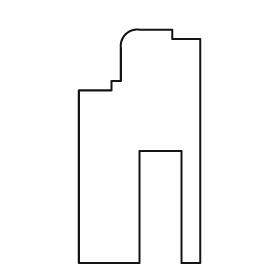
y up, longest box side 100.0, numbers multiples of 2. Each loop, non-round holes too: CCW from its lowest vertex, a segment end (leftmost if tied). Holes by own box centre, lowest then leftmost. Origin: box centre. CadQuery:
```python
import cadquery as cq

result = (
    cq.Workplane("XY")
    .moveTo(-26.0, -50.0)
    .lineTo(0.0, -50.0)
    .lineTo(0.0, -2.0)
    .lineTo(18.0, -2.0)
    .lineTo(18.0, -50.0)
    .lineTo(26.0, -50.0)
    .lineTo(26.0, 46.0)
    .lineTo(14.0, 46.0)
    .lineTo(14.0, 50.0)
    .lineTo(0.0, 50.0)
    .threePointArc((-6.0, 48.0), (-8.0, 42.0))
    .lineTo(-8.0, 28.0)
    .lineTo(-12.0, 28.0)
    .lineTo(-12.0, 24.0)
    .lineTo(-26.0, 24.0)
    .close()
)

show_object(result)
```